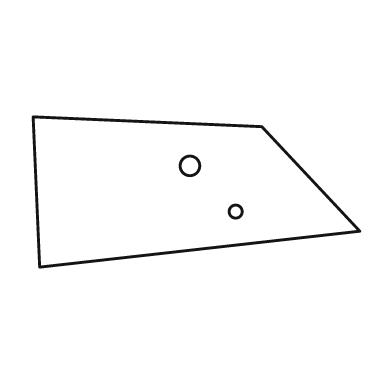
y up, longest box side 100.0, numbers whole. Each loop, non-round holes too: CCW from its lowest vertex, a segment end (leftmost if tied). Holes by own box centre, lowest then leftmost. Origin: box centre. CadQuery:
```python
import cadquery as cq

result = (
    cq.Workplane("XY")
    .moveTo(-48.0, -23.0)
    .lineTo(50.0, -12.0)
    .lineTo(20.0, 20.0)
    .lineTo(-50.0, 23.0)
    .close()
    .moveTo(12.0, -6.0)
    .circle(2.0)
    .moveTo(-2.0, 8.0)
    .circle(3.0)
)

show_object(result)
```